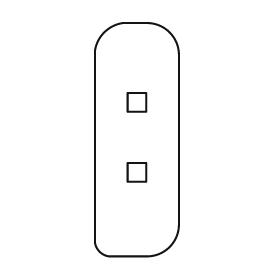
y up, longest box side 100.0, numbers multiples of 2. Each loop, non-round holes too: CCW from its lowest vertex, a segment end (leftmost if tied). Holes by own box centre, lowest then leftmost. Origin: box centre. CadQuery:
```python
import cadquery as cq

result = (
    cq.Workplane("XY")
    .moveTo(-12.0, -50.0)
    .lineTo(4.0, -50.0)
    .threePointArc((14.0, -46.0), (18.0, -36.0))
    .lineTo(18.0, 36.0)
    .threePointArc((14.0, 46.0), (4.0, 50.0))
    .lineTo(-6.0, 50.0)
    .threePointArc((-14.0, 46.0), (-18.0, 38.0))
    .lineTo(-18.0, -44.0)
    .threePointArc((-16.0, -48.0), (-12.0, -50.0))
    .close()
    .moveTo(-4.0, -18.0)
    .lineTo(4.0, -18.0)
    .lineTo(4.0, -10.0)
    .lineTo(-4.0, -10.0)
    .close()
    .moveTo(-4.0, 12.0)
    .lineTo(4.0, 12.0)
    .lineTo(4.0, 20.0)
    .lineTo(-4.0, 20.0)
    .close()
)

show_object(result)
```